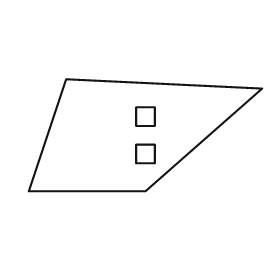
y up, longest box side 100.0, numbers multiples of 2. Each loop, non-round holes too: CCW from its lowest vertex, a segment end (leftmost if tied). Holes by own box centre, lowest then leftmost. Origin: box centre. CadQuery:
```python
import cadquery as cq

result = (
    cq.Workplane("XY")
    .moveTo(-50.0, -24.0)
    .lineTo(0.0, -24.0)
    .lineTo(50.0, 20.0)
    .lineTo(-34.0, 24.0)
    .close()
    .moveTo(-4.0, -12.0)
    .lineTo(4.0, -12.0)
    .lineTo(4.0, -4.0)
    .lineTo(-4.0, -4.0)
    .close()
    .moveTo(-4.0, 4.0)
    .lineTo(4.0, 4.0)
    .lineTo(4.0, 12.0)
    .lineTo(-4.0, 12.0)
    .close()
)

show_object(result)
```